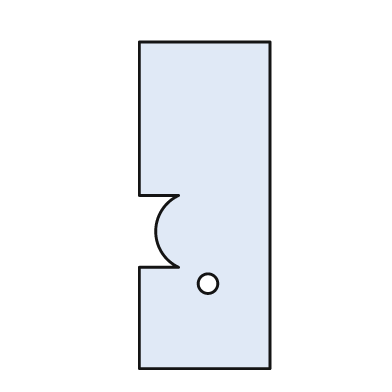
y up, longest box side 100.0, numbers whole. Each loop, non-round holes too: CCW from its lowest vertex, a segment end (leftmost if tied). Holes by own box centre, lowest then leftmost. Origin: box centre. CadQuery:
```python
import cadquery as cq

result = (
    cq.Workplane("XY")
    .moveTo(-20.0, -50.0)
    .lineTo(20.0, -50.0)
    .lineTo(20.0, 50.0)
    .lineTo(-20.0, 50.0)
    .lineTo(-20.0, 3.0)
    .lineTo(-8.0, 3.0)
    .threePointArc((-15.0, -8.0), (-8.0, -19.0))
    .lineTo(-20.0, -19.0)
    .close()
    .moveTo(1.0, -24.0)
    .circle(3.0)
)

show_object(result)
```